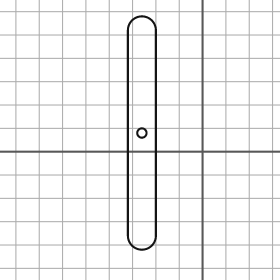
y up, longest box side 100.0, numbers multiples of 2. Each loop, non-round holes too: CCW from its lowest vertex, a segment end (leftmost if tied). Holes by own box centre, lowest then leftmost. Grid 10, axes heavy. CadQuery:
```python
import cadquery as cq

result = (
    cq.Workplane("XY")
    .moveTo(-32.0, -36.0)
    .threePointArc((-26.0, -42.0), (-20.0, -36.0))
    .lineTo(-20.0, 52.0)
    .threePointArc((-26.0, 58.0), (-32.0, 52.0))
    .close()
    .moveTo(-26.0, 8.0)
    .circle(2.0)
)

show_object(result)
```